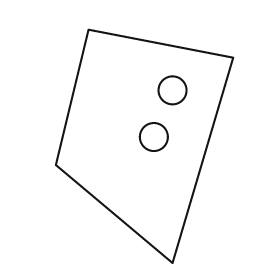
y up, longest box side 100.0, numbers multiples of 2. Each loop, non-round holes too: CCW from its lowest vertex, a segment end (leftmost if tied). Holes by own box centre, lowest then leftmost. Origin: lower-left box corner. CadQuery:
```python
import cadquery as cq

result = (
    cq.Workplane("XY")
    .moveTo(50.0, 0.0)
    .lineTo(76.0, 88.0)
    .lineTo(14.0, 100.0)
    .lineTo(0.0, 42.0)
    .close()
    .moveTo(42.0, 54.0)
    .circle(6.0)
    .moveTo(50.0, 74.0)
    .circle(6.0)
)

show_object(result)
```